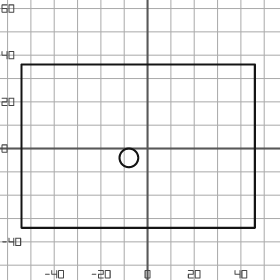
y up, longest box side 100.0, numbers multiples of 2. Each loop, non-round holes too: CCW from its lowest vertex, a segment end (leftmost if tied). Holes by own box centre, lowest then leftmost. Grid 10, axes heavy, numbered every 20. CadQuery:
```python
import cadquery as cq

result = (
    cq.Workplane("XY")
    .moveTo(-54.0, -34.0)
    .lineTo(46.0, -34.0)
    .lineTo(46.0, 36.0)
    .lineTo(-54.0, 36.0)
    .close()
    .moveTo(-8.0, -4.0)
    .circle(4.0)
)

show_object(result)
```